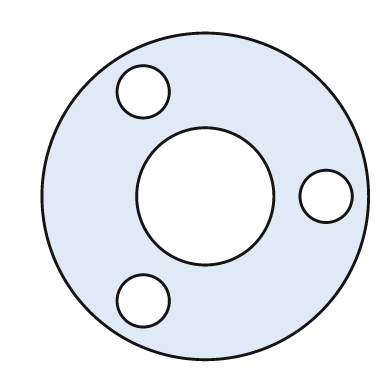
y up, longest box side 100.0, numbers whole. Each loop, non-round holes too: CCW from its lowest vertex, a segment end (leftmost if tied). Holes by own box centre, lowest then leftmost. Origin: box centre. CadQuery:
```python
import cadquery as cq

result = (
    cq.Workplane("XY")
    .moveTo(0.0, 0.0)
    .circle(50.0)
    .moveTo(-19.0, -32.0)
    .circle(8.0)
    .moveTo(0.0, 0.0)
    .circle(21.0)
    .moveTo(37.0, 0.0)
    .circle(8.0)
    .moveTo(-19.0, 32.0)
    .circle(8.0)
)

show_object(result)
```